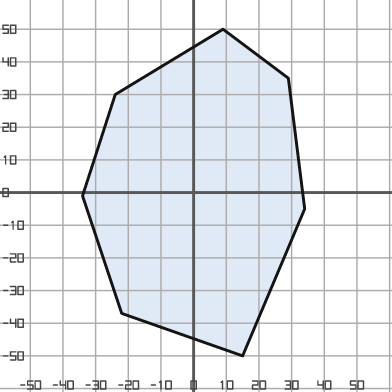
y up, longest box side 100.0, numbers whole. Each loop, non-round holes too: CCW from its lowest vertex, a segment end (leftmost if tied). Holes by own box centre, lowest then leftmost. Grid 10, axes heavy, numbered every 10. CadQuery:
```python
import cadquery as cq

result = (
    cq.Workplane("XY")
    .moveTo(15.0, -50.0)
    .lineTo(34.0, -5.0)
    .lineTo(29.0, 35.0)
    .lineTo(9.0, 50.0)
    .lineTo(-24.0, 30.0)
    .lineTo(-34.0, -1.0)
    .lineTo(-22.0, -37.0)
    .close()
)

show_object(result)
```